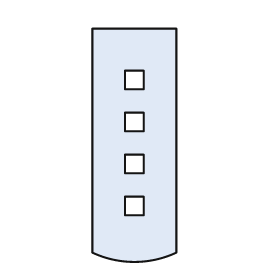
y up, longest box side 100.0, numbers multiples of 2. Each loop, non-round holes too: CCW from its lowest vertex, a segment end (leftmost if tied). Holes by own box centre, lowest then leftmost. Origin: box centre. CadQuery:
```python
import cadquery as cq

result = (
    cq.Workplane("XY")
    .moveTo(-18.0, -46.0)
    .threePointArc((0.0, -50.0), (18.0, -46.0))
    .lineTo(18.0, 50.0)
    .lineTo(-18.0, 50.0)
    .close()
    .moveTo(-4.0, -30.0)
    .lineTo(4.0, -30.0)
    .lineTo(4.0, -22.0)
    .lineTo(-4.0, -22.0)
    .close()
    .moveTo(-4.0, -12.0)
    .lineTo(4.0, -12.0)
    .lineTo(4.0, -4.0)
    .lineTo(-4.0, -4.0)
    .close()
    .moveTo(-4.0, 6.0)
    .lineTo(4.0, 6.0)
    .lineTo(4.0, 14.0)
    .lineTo(-4.0, 14.0)
    .close()
    .moveTo(-4.0, 24.0)
    .lineTo(4.0, 24.0)
    .lineTo(4.0, 32.0)
    .lineTo(-4.0, 32.0)
    .close()
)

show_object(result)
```